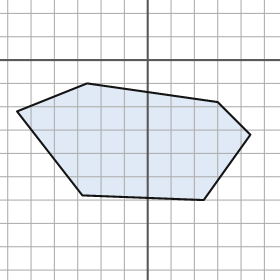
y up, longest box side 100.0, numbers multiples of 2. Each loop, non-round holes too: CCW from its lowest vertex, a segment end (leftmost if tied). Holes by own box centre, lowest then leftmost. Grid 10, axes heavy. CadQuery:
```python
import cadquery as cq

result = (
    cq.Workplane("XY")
    .moveTo(24.0, -60.0)
    .lineTo(44.0, -32.0)
    .lineTo(30.0, -18.0)
    .lineTo(-26.0, -10.0)
    .lineTo(-56.0, -22.0)
    .lineTo(-28.0, -58.0)
    .close()
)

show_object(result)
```